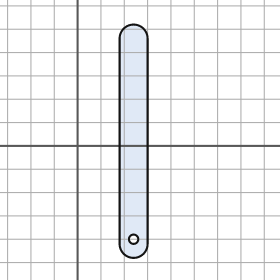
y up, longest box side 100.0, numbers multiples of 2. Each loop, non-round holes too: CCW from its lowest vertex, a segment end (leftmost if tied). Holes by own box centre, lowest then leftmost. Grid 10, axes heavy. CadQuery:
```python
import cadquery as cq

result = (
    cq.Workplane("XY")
    .moveTo(18.0, -42.0)
    .threePointArc((24.0, -48.0), (30.0, -42.0))
    .lineTo(30.0, 46.0)
    .threePointArc((24.0, 52.0), (18.0, 46.0))
    .close()
    .moveTo(24.0, -40.0)
    .circle(2.0)
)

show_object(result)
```